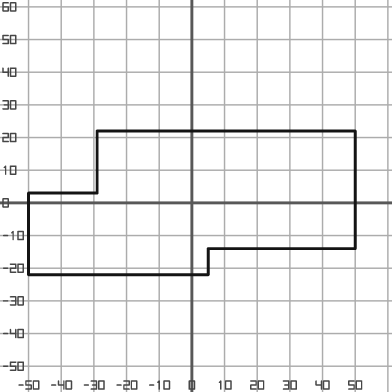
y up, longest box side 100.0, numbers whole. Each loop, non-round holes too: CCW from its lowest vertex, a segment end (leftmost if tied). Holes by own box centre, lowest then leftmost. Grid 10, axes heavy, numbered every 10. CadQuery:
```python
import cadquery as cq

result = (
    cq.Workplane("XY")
    .moveTo(-50.0, -22.0)
    .lineTo(5.0, -22.0)
    .lineTo(5.0, -14.0)
    .lineTo(50.0, -14.0)
    .lineTo(50.0, 22.0)
    .lineTo(-29.0, 22.0)
    .lineTo(-29.0, 3.0)
    .lineTo(-50.0, 3.0)
    .close()
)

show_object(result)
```